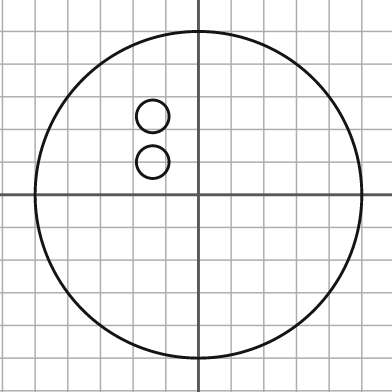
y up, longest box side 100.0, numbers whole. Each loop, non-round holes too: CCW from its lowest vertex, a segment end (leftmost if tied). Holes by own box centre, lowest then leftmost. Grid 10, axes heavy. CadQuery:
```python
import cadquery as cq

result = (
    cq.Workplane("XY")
    .moveTo(0.0, 0.0)
    .circle(50.0)
    .moveTo(-14.0, 10.0)
    .circle(5.0)
    .moveTo(-14.0, 24.0)
    .circle(5.0)
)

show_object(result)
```